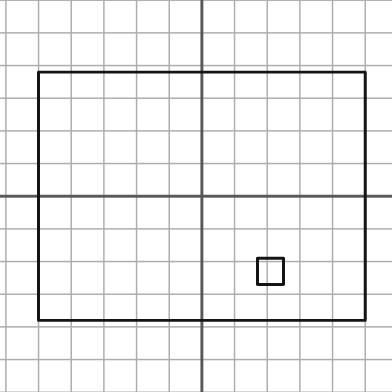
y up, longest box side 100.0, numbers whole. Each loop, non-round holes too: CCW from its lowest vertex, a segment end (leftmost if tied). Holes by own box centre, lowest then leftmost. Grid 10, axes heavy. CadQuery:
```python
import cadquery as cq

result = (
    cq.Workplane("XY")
    .moveTo(-50.0, -38.0)
    .lineTo(50.0, -38.0)
    .lineTo(50.0, 38.0)
    .lineTo(-50.0, 38.0)
    .close()
    .moveTo(17.0, -27.0)
    .lineTo(25.0, -27.0)
    .lineTo(25.0, -19.0)
    .lineTo(17.0, -19.0)
    .close()
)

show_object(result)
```